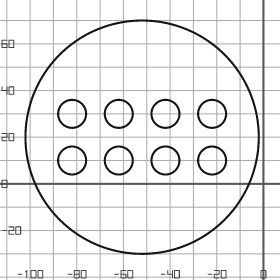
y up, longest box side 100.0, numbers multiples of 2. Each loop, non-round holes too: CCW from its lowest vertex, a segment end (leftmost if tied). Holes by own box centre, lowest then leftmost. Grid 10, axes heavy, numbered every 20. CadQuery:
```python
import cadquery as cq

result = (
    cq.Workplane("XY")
    .moveTo(-52.0, 20.0)
    .circle(50.0)
    .moveTo(-82.0, 10.0)
    .circle(6.0)
    .moveTo(-62.0, 10.0)
    .circle(6.0)
    .moveTo(-42.0, 10.0)
    .circle(6.0)
    .moveTo(-22.0, 10.0)
    .circle(6.0)
    .moveTo(-82.0, 30.0)
    .circle(6.0)
    .moveTo(-62.0, 30.0)
    .circle(6.0)
    .moveTo(-42.0, 30.0)
    .circle(6.0)
    .moveTo(-22.0, 30.0)
    .circle(6.0)
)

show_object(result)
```